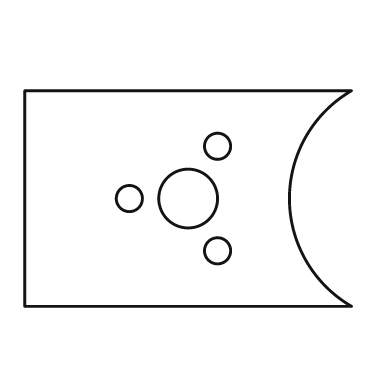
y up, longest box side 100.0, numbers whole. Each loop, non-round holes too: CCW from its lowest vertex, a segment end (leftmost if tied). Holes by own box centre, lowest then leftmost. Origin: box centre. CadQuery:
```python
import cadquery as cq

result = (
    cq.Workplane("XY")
    .moveTo(-50.0, -33.0)
    .lineTo(50.0, -33.0)
    .threePointArc((31.0, 0.0), (50.0, 33.0))
    .lineTo(-50.0, 33.0)
    .close()
    .moveTo(9.0, -16.0)
    .circle(4.0)
    .moveTo(-18.0, 0.0)
    .circle(4.0)
    .moveTo(0.0, 0.0)
    .circle(9.0)
    .moveTo(9.0, 16.0)
    .circle(4.0)
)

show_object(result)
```